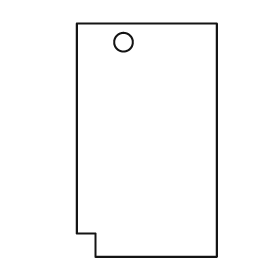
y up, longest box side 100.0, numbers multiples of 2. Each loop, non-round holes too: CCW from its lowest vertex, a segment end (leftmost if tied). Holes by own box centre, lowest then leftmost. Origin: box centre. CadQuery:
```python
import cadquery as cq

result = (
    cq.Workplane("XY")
    .moveTo(-22.0, -50.0)
    .lineTo(30.0, -50.0)
    .lineTo(30.0, 50.0)
    .lineTo(-30.0, 50.0)
    .lineTo(-30.0, -40.0)
    .lineTo(-22.0, -40.0)
    .close()
    .moveTo(-10.0, 42.0)
    .circle(4.0)
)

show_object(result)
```